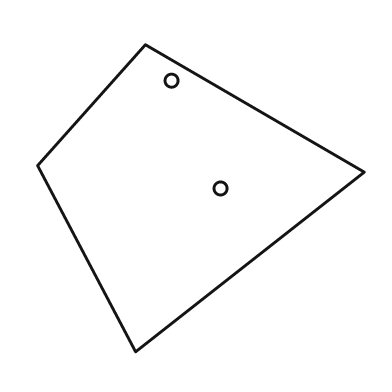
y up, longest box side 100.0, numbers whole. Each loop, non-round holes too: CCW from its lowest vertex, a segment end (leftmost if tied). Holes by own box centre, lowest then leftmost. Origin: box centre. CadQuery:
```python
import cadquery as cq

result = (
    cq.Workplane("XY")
    .moveTo(-20.0, -47.0)
    .lineTo(50.0, 8.0)
    .lineTo(-17.0, 47.0)
    .lineTo(-50.0, 10.0)
    .close()
    .moveTo(6.0, 3.0)
    .circle(2.0)
    .moveTo(-9.0, 36.0)
    .circle(2.0)
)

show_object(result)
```